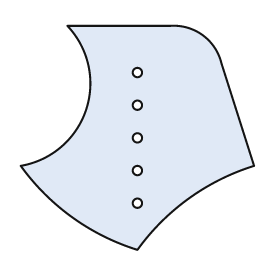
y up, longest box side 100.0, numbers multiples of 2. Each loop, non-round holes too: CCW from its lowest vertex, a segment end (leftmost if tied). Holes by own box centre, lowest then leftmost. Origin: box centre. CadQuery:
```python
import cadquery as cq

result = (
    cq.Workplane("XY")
    .moveTo(0.0, -48.0)
    .threePointArc((22.0, -26.0), (50.0, -12.0))
    .lineTo(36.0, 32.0)
    .threePointArc((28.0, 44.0), (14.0, 48.0))
    .lineTo(-30.0, 48.0)
    .threePointArc((-22.0, 12.0), (-50.0, -12.0))
    .threePointArc((-28.0, -34.0), (0.0, -48.0))
    .close()
    .moveTo(0.0, -28.0)
    .circle(2.0)
    .moveTo(0.0, -14.0)
    .circle(2.0)
    .moveTo(0.0, 0.0)
    .circle(2.0)
    .moveTo(0.0, 14.0)
    .circle(2.0)
    .moveTo(0.0, 28.0)
    .circle(2.0)
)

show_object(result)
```